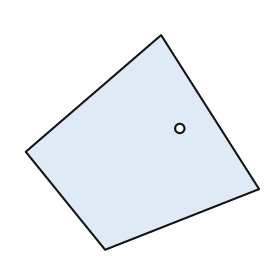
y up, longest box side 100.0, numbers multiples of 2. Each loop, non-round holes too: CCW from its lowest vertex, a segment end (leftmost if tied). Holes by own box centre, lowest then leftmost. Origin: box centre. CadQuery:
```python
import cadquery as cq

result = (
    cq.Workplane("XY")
    .moveTo(-16.0, -46.0)
    .lineTo(50.0, -20.0)
    .lineTo(8.0, 46.0)
    .lineTo(-50.0, -4.0)
    .close()
    .moveTo(16.0, 6.0)
    .circle(2.0)
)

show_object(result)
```